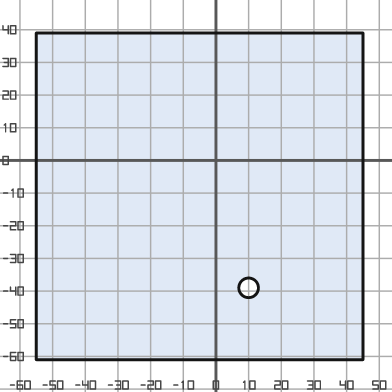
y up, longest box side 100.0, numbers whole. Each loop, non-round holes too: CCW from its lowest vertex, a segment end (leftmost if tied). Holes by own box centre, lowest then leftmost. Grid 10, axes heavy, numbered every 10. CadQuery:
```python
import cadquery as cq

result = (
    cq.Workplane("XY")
    .moveTo(-55.0, -61.0)
    .lineTo(45.0, -61.0)
    .lineTo(45.0, 39.0)
    .lineTo(-55.0, 39.0)
    .close()
    .moveTo(10.0, -39.0)
    .circle(3.0)
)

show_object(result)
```